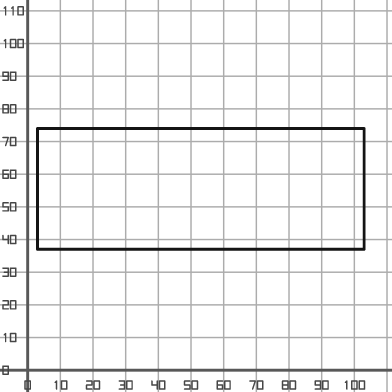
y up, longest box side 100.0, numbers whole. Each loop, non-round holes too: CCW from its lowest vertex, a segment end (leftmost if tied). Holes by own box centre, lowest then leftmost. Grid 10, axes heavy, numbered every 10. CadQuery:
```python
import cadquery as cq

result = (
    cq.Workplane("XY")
    .moveTo(3.0, 37.0)
    .lineTo(103.0, 37.0)
    .lineTo(103.0, 74.0)
    .lineTo(3.0, 74.0)
    .close()
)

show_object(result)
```